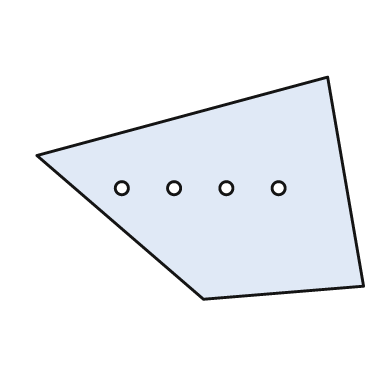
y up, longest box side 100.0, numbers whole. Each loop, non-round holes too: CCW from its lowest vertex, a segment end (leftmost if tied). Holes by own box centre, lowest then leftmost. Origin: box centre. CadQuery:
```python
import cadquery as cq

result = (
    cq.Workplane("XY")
    .moveTo(1.0, -34.0)
    .lineTo(50.0, -30.0)
    .lineTo(39.0, 34.0)
    .lineTo(-50.0, 10.0)
    .close()
    .moveTo(-24.0, 0.0)
    .circle(2.0)
    .moveTo(-8.0, 0.0)
    .circle(2.0)
    .moveTo(8.0, 0.0)
    .circle(2.0)
    .moveTo(24.0, 0.0)
    .circle(2.0)
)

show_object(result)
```